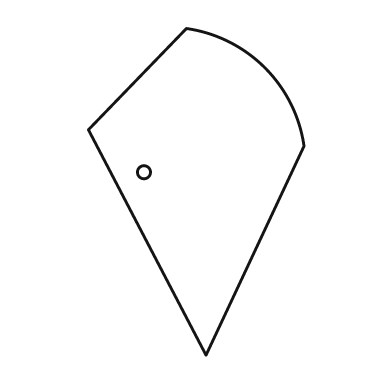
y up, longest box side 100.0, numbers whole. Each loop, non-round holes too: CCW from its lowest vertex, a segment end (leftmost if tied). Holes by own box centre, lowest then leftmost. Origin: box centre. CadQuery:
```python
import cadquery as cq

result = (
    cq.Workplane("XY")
    .moveTo(3.0, -50.0)
    .lineTo(33.0, 14.0)
    .threePointArc((21.0, 38.0), (-3.0, 50.0))
    .lineTo(-33.0, 19.0)
    .close()
    .moveTo(-16.0, 6.0)
    .circle(2.0)
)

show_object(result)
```